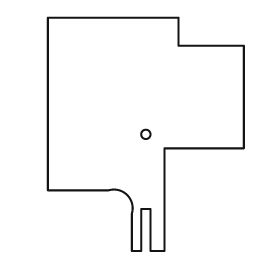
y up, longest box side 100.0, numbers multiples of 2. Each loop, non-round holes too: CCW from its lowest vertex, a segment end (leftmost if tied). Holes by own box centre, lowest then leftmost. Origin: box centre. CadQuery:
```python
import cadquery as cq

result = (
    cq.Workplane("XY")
    .moveTo(-6.0, -50.0)
    .lineTo(-2.0, -50.0)
    .lineTo(-2.0, -32.0)
    .lineTo(2.0, -32.0)
    .lineTo(2.0, -50.0)
    .lineTo(8.0, -50.0)
    .lineTo(8.0, -6.0)
    .lineTo(42.0, -6.0)
    .lineTo(42.0, 38.0)
    .lineTo(14.0, 38.0)
    .lineTo(14.0, 50.0)
    .lineTo(-42.0, 50.0)
    .lineTo(-42.0, -24.0)
    .lineTo(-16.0, -24.0)
    .threePointArc((-8.0, -26.0), (-6.0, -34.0))
    .close()
    .moveTo(0.0, 0.0)
    .circle(2.0)
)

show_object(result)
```